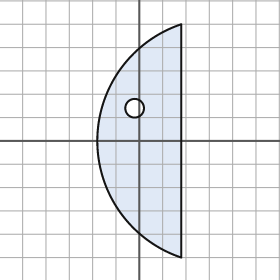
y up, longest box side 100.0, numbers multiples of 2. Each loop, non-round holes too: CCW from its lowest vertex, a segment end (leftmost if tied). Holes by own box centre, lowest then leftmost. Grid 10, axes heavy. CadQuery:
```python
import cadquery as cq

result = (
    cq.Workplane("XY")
    .moveTo(18.0, -50.0)
    .lineTo(18.0, 50.0)
    .threePointArc((-18.0, 0.0), (18.0, -50.0))
    .close()
    .moveTo(-2.0, 14.0)
    .circle(4.0)
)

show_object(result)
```